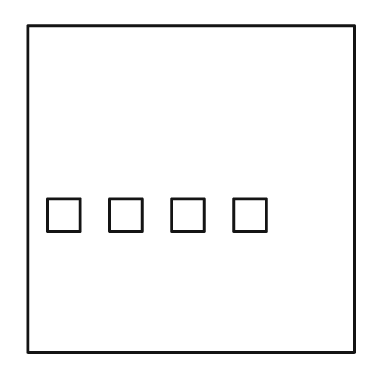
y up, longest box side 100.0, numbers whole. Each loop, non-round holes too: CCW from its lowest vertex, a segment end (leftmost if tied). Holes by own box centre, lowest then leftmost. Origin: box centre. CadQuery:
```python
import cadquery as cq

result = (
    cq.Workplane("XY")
    .moveTo(-50.0, -50.0)
    .lineTo(50.0, -50.0)
    .lineTo(50.0, 50.0)
    .lineTo(-50.0, 50.0)
    .close()
    .moveTo(-44.0, -13.0)
    .lineTo(-34.0, -13.0)
    .lineTo(-34.0, -3.0)
    .lineTo(-44.0, -3.0)
    .close()
    .moveTo(-25.0, -13.0)
    .lineTo(-15.0, -13.0)
    .lineTo(-15.0, -3.0)
    .lineTo(-25.0, -3.0)
    .close()
    .moveTo(-6.0, -13.0)
    .lineTo(4.0, -13.0)
    .lineTo(4.0, -3.0)
    .lineTo(-6.0, -3.0)
    .close()
    .moveTo(13.0, -13.0)
    .lineTo(23.0, -13.0)
    .lineTo(23.0, -3.0)
    .lineTo(13.0, -3.0)
    .close()
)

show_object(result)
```